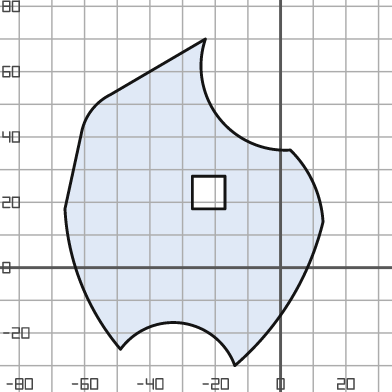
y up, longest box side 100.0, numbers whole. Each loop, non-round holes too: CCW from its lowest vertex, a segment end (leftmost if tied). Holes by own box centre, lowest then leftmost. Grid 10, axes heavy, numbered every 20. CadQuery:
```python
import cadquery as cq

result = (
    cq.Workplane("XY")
    .moveTo(-14.0, -30.0)
    .threePointArc((3.0, -10.0), (13.0, 14.0))
    .threePointArc((10.0, 26.0), (3.0, 36.0))
    .threePointArc((-19.0, 46.0), (-23.0, 70.0))
    .lineTo(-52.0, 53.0)
    .threePointArc((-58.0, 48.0), (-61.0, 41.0))
    .lineTo(-66.0, 18.0)
    .threePointArc((-61.0, -5.0), (-49.0, -25.0))
    .threePointArc((-30.0, -17.0), (-14.0, -30.0))
    .close()
    .moveTo(-27.0, 18.0)
    .lineTo(-17.0, 18.0)
    .lineTo(-17.0, 28.0)
    .lineTo(-27.0, 28.0)
    .close()
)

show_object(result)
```